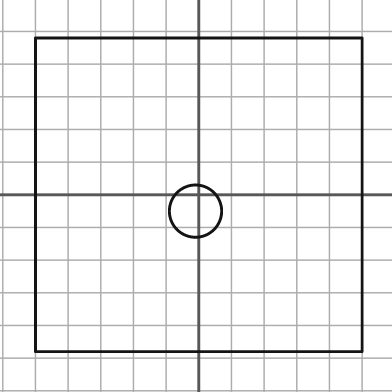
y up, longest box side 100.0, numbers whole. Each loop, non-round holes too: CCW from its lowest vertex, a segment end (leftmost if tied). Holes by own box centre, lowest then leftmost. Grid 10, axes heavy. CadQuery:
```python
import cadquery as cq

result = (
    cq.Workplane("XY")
    .moveTo(-50.0, -48.0)
    .lineTo(50.0, -48.0)
    .lineTo(50.0, 48.0)
    .lineTo(-50.0, 48.0)
    .close()
    .moveTo(-1.0, -5.0)
    .circle(8.0)
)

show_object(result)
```